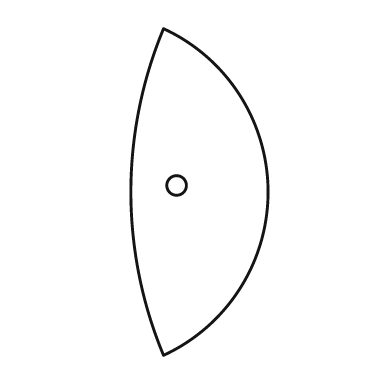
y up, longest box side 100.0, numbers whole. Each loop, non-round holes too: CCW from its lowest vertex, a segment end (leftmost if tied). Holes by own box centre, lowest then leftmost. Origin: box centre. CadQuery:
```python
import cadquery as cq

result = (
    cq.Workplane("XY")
    .moveTo(-11.0, -50.0)
    .threePointArc((21.0, 0.0), (-11.0, 50.0))
    .threePointArc((-21.0, 0.0), (-11.0, -50.0))
    .close()
    .moveTo(-7.0, 2.0)
    .circle(3.0)
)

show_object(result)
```